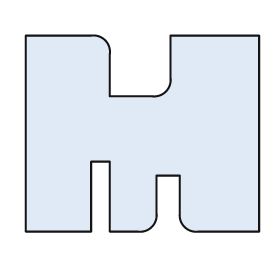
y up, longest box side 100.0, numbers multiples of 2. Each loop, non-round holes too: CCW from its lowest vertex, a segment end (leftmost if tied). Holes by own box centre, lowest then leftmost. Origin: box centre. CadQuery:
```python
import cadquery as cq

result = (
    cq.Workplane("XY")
    .moveTo(-50.0, -42.0)
    .lineTo(-22.0, -42.0)
    .lineTo(-22.0, -12.0)
    .lineTo(-14.0, -12.0)
    .lineTo(-14.0, -42.0)
    .lineTo(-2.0, -42.0)
    .threePointArc((4.0, -40.0), (6.0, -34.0))
    .lineTo(6.0, -18.0)
    .lineTo(16.0, -18.0)
    .lineTo(16.0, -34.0)
    .threePointArc((18.0, -40.0), (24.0, -42.0))
    .lineTo(50.0, -42.0)
    .lineTo(50.0, 42.0)
    .lineTo(12.0, 42.0)
    .lineTo(12.0, 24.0)
    .threePointArc((10.0, 18.0), (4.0, 16.0))
    .lineTo(-14.0, 16.0)
    .lineTo(-14.0, 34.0)
    .threePointArc((-16.0, 40.0), (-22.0, 42.0))
    .lineTo(-50.0, 42.0)
    .close()
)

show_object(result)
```